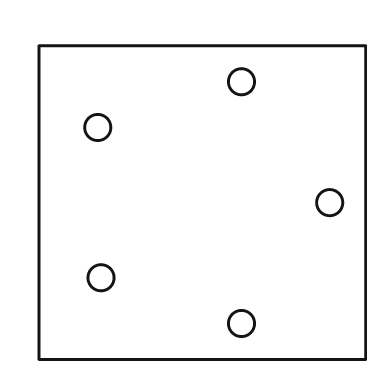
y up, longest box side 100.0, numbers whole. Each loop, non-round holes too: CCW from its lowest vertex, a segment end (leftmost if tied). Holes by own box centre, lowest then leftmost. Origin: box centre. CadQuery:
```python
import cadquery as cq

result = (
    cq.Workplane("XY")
    .moveTo(-50.0, -48.0)
    .lineTo(50.0, -48.0)
    .lineTo(50.0, 48.0)
    .lineTo(-50.0, 48.0)
    .close()
    .moveTo(12.0, -37.0)
    .circle(4.0)
    .moveTo(-31.0, -23.0)
    .circle(4.0)
    .moveTo(39.0, 0.0)
    .circle(4.0)
    .moveTo(-32.0, 23.0)
    .circle(4.0)
    .moveTo(12.0, 37.0)
    .circle(4.0)
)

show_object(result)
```